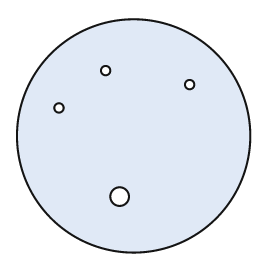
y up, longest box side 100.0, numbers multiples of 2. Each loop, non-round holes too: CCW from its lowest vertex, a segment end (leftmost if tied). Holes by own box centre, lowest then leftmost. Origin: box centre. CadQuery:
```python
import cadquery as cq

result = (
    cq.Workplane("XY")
    .moveTo(0.0, 0.0)
    .circle(50.0)
    .moveTo(-6.0, -26.0)
    .circle(4.0)
    .moveTo(-32.0, 12.0)
    .circle(2.0)
    .moveTo(24.0, 22.0)
    .circle(2.0)
    .moveTo(-12.0, 28.0)
    .circle(2.0)
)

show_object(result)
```